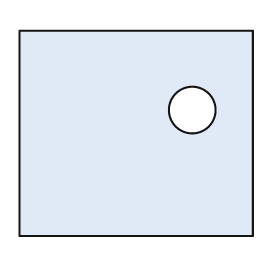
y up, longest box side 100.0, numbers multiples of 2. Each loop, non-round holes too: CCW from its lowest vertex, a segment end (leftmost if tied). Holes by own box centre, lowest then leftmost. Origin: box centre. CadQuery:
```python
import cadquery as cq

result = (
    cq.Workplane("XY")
    .moveTo(-50.0, -44.0)
    .lineTo(50.0, -44.0)
    .lineTo(50.0, 44.0)
    .lineTo(-50.0, 44.0)
    .close()
    .moveTo(24.0, 10.0)
    .circle(10.0)
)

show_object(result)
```